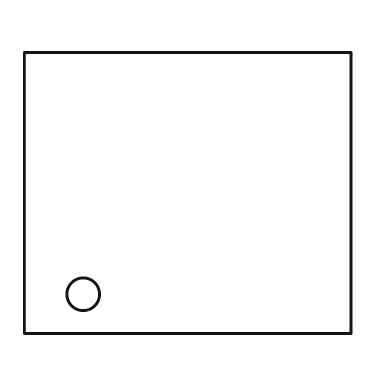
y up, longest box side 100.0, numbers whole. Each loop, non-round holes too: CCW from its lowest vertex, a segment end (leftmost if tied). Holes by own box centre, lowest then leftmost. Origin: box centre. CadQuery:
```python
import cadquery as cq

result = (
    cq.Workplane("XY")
    .moveTo(-50.0, -43.0)
    .lineTo(50.0, -43.0)
    .lineTo(50.0, 43.0)
    .lineTo(-50.0, 43.0)
    .close()
    .moveTo(-32.0, -31.0)
    .circle(5.0)
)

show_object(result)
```